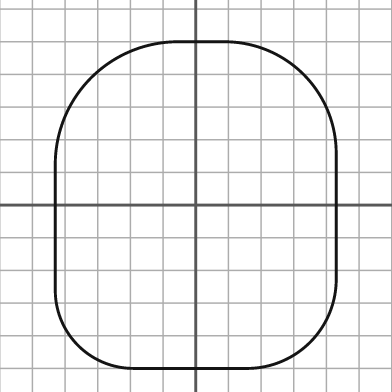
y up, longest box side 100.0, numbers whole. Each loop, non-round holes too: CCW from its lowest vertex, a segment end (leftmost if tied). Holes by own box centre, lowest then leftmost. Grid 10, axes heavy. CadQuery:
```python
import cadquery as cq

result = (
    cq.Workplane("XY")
    .moveTo(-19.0, -50.0)
    .lineTo(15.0, -50.0)
    .threePointArc((35.0, -42.0), (43.0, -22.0))
    .lineTo(43.0, 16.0)
    .threePointArc((33.0, 40.0), (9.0, 50.0))
    .lineTo(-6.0, 50.0)
    .threePointArc((-32.0, 39.0), (-43.0, 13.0))
    .lineTo(-43.0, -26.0)
    .threePointArc((-36.0, -43.0), (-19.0, -50.0))
    .close()
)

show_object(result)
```